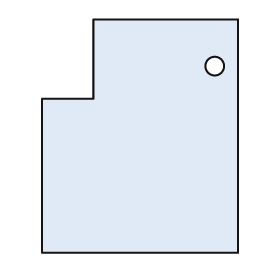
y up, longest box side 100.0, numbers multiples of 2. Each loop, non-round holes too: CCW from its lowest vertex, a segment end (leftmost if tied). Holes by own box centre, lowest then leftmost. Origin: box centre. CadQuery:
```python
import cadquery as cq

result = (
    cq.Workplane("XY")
    .moveTo(-42.0, -50.0)
    .lineTo(42.0, -50.0)
    .lineTo(42.0, 50.0)
    .lineTo(-20.0, 50.0)
    .lineTo(-20.0, 16.0)
    .lineTo(-42.0, 16.0)
    .close()
    .moveTo(32.0, 30.0)
    .circle(4.0)
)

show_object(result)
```